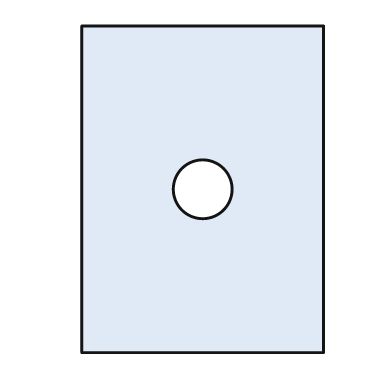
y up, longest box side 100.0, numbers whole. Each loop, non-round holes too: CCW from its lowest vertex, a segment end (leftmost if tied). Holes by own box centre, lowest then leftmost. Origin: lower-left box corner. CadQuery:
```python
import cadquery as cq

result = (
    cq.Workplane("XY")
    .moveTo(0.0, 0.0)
    .lineTo(74.0, 0.0)
    .lineTo(74.0, 100.0)
    .lineTo(0.0, 100.0)
    .close()
    .moveTo(37.0, 50.0)
    .circle(9.0)
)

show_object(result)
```